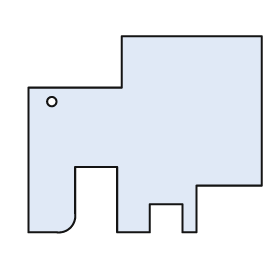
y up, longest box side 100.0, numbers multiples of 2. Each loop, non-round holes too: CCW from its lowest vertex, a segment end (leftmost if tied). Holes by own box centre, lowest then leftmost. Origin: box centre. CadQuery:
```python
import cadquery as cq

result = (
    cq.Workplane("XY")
    .moveTo(-50.0, -42.0)
    .lineTo(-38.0, -42.0)
    .threePointArc((-32.0, -40.0), (-30.0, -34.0))
    .lineTo(-30.0, -14.0)
    .lineTo(-12.0, -14.0)
    .lineTo(-12.0, -42.0)
    .lineTo(2.0, -42.0)
    .lineTo(2.0, -30.0)
    .lineTo(16.0, -30.0)
    .lineTo(16.0, -42.0)
    .lineTo(22.0, -42.0)
    .lineTo(22.0, -22.0)
    .lineTo(50.0, -22.0)
    .lineTo(50.0, 42.0)
    .lineTo(-10.0, 42.0)
    .lineTo(-10.0, 20.0)
    .lineTo(-50.0, 20.0)
    .close()
    .moveTo(-40.0, 14.0)
    .circle(2.0)
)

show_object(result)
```